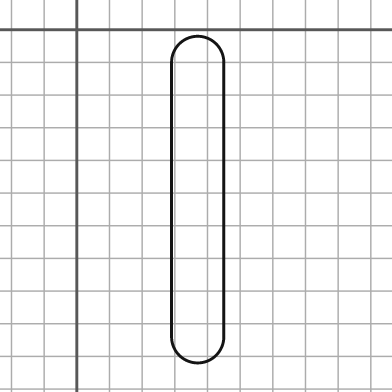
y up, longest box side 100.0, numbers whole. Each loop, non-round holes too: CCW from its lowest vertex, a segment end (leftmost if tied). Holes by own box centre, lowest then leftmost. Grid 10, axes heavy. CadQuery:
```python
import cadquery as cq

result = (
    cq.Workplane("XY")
    .moveTo(29.0, -94.0)
    .threePointArc((37.0, -102.0), (45.0, -94.0))
    .lineTo(45.0, -10.0)
    .threePointArc((37.0, -2.0), (29.0, -10.0))
    .close()
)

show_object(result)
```